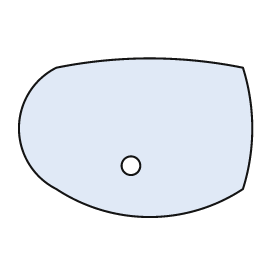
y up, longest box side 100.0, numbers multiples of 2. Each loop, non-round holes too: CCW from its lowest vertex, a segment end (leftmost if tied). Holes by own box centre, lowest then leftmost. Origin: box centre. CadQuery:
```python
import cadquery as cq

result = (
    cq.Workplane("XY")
    .moveTo(-34.0, -22.0)
    .threePointArc((6.0, -34.0), (46.0, -22.0))
    .threePointArc((50.0, 4.0), (46.0, 30.0))
    .threePointArc((6.0, 34.0), (-34.0, 30.0))
    .threePointArc((-50.0, 4.0), (-34.0, -22.0))
    .close()
    .moveTo(-2.0, -12.0)
    .circle(4.0)
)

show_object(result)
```